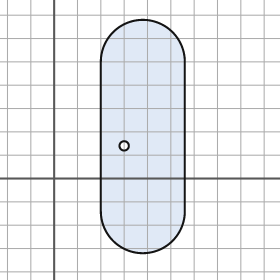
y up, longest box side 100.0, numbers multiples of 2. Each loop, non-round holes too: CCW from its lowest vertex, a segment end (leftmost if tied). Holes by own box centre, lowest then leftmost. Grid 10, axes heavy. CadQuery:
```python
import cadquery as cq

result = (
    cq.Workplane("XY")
    .moveTo(20.0, -14.0)
    .threePointArc((38.0, -32.0), (56.0, -14.0))
    .lineTo(56.0, 50.0)
    .threePointArc((38.0, 68.0), (20.0, 50.0))
    .close()
    .moveTo(30.0, 14.0)
    .circle(2.0)
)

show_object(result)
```